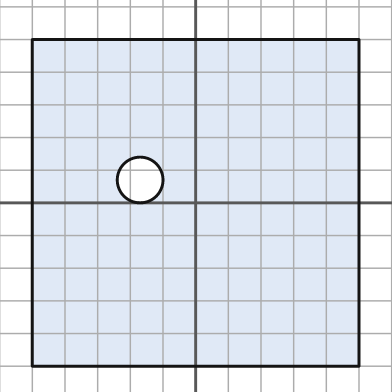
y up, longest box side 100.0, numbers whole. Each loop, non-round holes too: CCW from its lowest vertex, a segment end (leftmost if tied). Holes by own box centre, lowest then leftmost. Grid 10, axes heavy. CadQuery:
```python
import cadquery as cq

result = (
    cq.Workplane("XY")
    .moveTo(-50.0, -50.0)
    .lineTo(50.0, -50.0)
    .lineTo(50.0, 50.0)
    .lineTo(-50.0, 50.0)
    .close()
    .moveTo(-17.0, 7.0)
    .circle(7.0)
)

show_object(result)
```